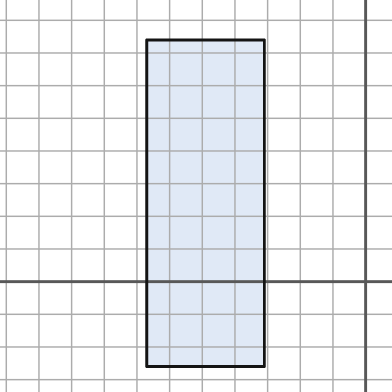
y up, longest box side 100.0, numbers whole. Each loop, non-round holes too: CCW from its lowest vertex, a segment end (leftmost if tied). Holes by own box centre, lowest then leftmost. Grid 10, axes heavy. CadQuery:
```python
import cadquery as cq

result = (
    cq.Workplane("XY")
    .moveTo(-67.0, -26.0)
    .lineTo(-31.0, -26.0)
    .lineTo(-31.0, 74.0)
    .lineTo(-67.0, 74.0)
    .close()
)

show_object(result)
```